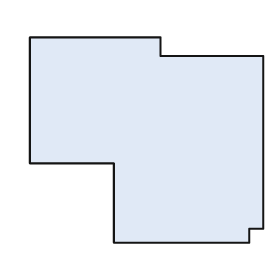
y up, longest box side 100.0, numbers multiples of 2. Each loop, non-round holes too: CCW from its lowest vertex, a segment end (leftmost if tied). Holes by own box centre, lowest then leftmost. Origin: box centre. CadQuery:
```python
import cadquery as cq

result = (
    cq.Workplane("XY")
    .moveTo(-14.0, -44.0)
    .lineTo(44.0, -44.0)
    .lineTo(44.0, -38.0)
    .lineTo(50.0, -38.0)
    .lineTo(50.0, 36.0)
    .lineTo(6.0, 36.0)
    .lineTo(6.0, 44.0)
    .lineTo(-50.0, 44.0)
    .lineTo(-50.0, -10.0)
    .lineTo(-14.0, -10.0)
    .close()
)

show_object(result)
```